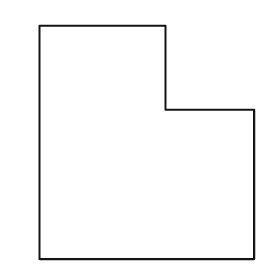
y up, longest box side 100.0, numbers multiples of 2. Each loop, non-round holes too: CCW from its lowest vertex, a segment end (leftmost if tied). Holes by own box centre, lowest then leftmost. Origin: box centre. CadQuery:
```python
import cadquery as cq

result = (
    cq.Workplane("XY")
    .moveTo(-46.0, -50.0)
    .lineTo(46.0, -50.0)
    .lineTo(46.0, 14.0)
    .lineTo(8.0, 14.0)
    .lineTo(8.0, 50.0)
    .lineTo(-46.0, 50.0)
    .close()
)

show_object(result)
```